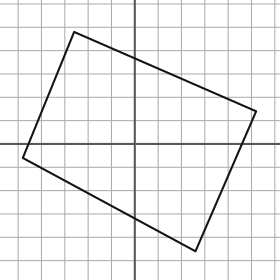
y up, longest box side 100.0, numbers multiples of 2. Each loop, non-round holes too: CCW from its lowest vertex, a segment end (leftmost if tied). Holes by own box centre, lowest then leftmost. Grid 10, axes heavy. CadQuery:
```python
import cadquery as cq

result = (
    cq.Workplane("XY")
    .moveTo(26.0, -46.0)
    .lineTo(52.0, 14.0)
    .lineTo(-26.0, 48.0)
    .lineTo(-48.0, -6.0)
    .close()
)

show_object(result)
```